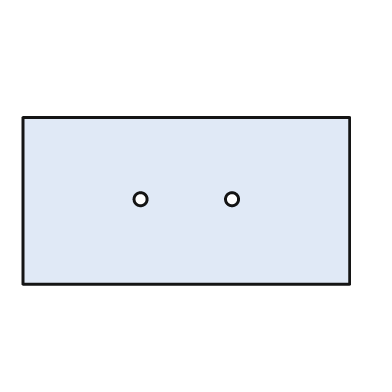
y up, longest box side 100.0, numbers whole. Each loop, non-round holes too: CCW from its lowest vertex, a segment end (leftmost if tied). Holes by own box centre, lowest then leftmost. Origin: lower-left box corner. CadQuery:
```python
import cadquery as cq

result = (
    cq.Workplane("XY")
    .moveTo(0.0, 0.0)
    .lineTo(100.0, 0.0)
    .lineTo(100.0, 51.0)
    .lineTo(0.0, 51.0)
    .close()
    .moveTo(36.0, 26.0)
    .circle(2.0)
    .moveTo(64.0, 26.0)
    .circle(2.0)
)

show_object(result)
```